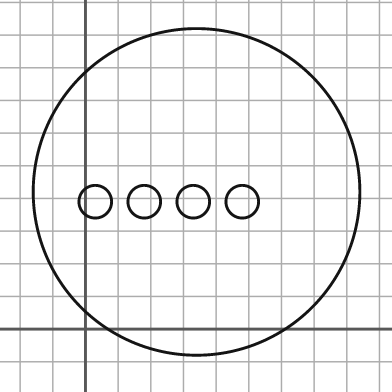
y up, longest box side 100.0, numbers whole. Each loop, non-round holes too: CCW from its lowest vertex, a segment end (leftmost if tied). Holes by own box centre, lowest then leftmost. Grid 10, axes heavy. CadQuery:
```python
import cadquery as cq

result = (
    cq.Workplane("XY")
    .moveTo(34.0, 42.0)
    .circle(50.0)
    .moveTo(3.0, 39.0)
    .circle(5.0)
    .moveTo(18.0, 39.0)
    .circle(5.0)
    .moveTo(33.0, 39.0)
    .circle(5.0)
    .moveTo(48.0, 39.0)
    .circle(5.0)
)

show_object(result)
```